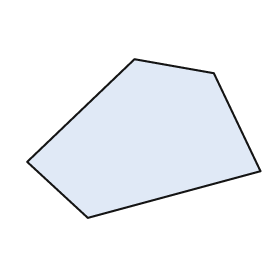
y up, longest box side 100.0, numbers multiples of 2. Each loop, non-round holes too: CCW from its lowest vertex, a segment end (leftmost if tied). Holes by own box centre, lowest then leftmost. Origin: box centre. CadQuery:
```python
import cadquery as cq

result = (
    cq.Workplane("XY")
    .moveTo(-24.0, -34.0)
    .lineTo(50.0, -14.0)
    .lineTo(30.0, 28.0)
    .lineTo(-4.0, 34.0)
    .lineTo(-50.0, -10.0)
    .close()
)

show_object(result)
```